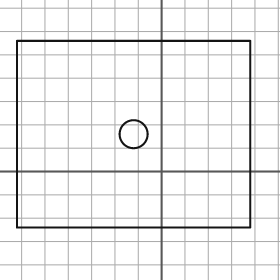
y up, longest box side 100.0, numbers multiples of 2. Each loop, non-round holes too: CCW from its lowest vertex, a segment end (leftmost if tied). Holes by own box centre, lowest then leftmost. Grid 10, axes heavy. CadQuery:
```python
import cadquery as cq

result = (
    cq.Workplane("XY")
    .moveTo(-62.0, -24.0)
    .lineTo(38.0, -24.0)
    .lineTo(38.0, 56.0)
    .lineTo(-62.0, 56.0)
    .close()
    .moveTo(-12.0, 16.0)
    .circle(6.0)
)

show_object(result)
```